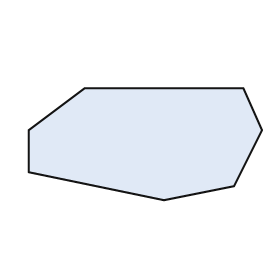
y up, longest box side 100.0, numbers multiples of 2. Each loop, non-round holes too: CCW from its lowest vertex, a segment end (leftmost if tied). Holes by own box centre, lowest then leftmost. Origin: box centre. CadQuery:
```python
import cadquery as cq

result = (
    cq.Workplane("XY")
    .moveTo(8.0, -24.0)
    .lineTo(38.0, -18.0)
    .lineTo(50.0, 6.0)
    .lineTo(42.0, 24.0)
    .lineTo(-26.0, 24.0)
    .lineTo(-50.0, 6.0)
    .lineTo(-50.0, -12.0)
    .close()
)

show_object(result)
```